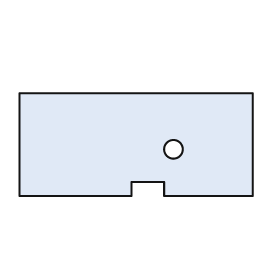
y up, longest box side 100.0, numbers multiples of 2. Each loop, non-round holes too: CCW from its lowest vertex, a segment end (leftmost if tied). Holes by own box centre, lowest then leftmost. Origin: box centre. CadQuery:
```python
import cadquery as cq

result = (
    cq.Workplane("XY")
    .moveTo(-50.0, -22.0)
    .lineTo(-2.0, -22.0)
    .lineTo(-2.0, -16.0)
    .lineTo(12.0, -16.0)
    .lineTo(12.0, -22.0)
    .lineTo(50.0, -22.0)
    .lineTo(50.0, 22.0)
    .lineTo(-50.0, 22.0)
    .close()
    .moveTo(16.0, -2.0)
    .circle(4.0)
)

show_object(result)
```